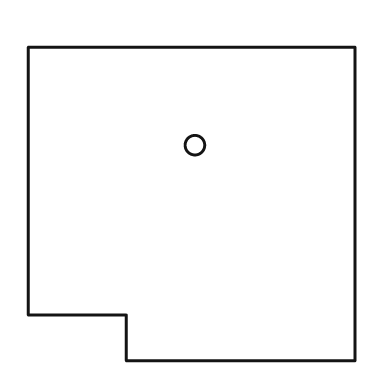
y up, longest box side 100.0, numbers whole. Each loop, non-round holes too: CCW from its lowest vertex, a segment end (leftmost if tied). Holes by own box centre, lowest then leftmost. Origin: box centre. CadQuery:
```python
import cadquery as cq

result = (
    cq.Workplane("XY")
    .moveTo(-20.0, -48.0)
    .lineTo(50.0, -48.0)
    .lineTo(50.0, 48.0)
    .lineTo(-50.0, 48.0)
    .lineTo(-50.0, -34.0)
    .lineTo(-20.0, -34.0)
    .close()
    .moveTo(1.0, 18.0)
    .circle(3.0)
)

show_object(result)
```